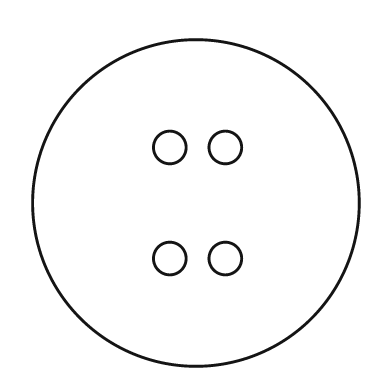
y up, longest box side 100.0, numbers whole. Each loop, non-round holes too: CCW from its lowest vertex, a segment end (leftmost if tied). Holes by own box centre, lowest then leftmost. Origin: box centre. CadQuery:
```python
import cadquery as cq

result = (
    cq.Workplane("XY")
    .moveTo(0.0, 0.0)
    .circle(50.0)
    .moveTo(-8.0, -17.0)
    .circle(5.0)
    .moveTo(9.0, -17.0)
    .circle(5.0)
    .moveTo(-8.0, 17.0)
    .circle(5.0)
    .moveTo(9.0, 17.0)
    .circle(5.0)
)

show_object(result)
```